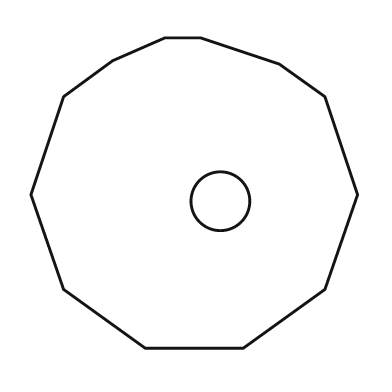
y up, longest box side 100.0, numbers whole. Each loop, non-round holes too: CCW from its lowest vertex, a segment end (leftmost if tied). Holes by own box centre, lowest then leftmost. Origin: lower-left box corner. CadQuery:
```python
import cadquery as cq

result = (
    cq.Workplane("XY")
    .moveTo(35.0, 0.0)
    .lineTo(65.0, 0.0)
    .lineTo(90.0, 18.0)
    .lineTo(100.0, 47.0)
    .lineTo(90.0, 77.0)
    .lineTo(76.0, 87.0)
    .lineTo(52.0, 95.0)
    .lineTo(41.0, 95.0)
    .lineTo(25.0, 88.0)
    .lineTo(10.0, 77.0)
    .lineTo(0.0, 47.0)
    .lineTo(10.0, 18.0)
    .close()
    .moveTo(58.0, 45.0)
    .circle(9.0)
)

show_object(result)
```